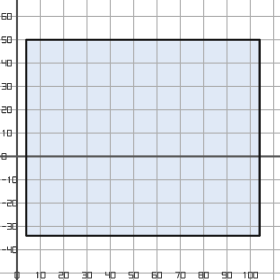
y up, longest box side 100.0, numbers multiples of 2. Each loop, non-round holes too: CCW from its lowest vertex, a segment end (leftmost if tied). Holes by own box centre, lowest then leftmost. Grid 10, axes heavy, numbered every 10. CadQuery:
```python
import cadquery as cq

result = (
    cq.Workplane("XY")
    .moveTo(4.0, -34.0)
    .lineTo(104.0, -34.0)
    .lineTo(104.0, 50.0)
    .lineTo(4.0, 50.0)
    .close()
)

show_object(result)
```